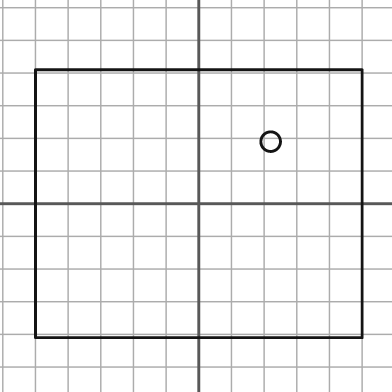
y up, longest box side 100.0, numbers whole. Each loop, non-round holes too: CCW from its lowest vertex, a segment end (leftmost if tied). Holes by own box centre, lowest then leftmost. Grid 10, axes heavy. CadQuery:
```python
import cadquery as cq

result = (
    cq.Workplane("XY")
    .moveTo(-50.0, -41.0)
    .lineTo(50.0, -41.0)
    .lineTo(50.0, 41.0)
    .lineTo(-50.0, 41.0)
    .close()
    .moveTo(22.0, 19.0)
    .circle(3.0)
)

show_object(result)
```